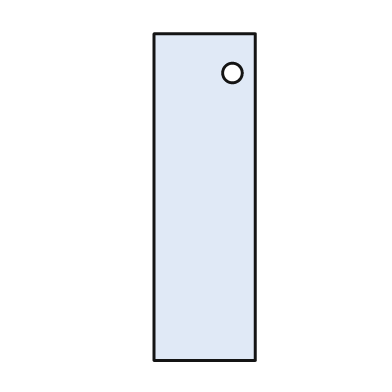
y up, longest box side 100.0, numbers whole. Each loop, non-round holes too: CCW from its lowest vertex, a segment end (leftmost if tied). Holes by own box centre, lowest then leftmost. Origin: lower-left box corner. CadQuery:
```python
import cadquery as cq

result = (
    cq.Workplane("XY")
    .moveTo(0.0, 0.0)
    .lineTo(31.0, 0.0)
    .lineTo(31.0, 100.0)
    .lineTo(0.0, 100.0)
    .close()
    .moveTo(24.0, 88.0)
    .circle(3.0)
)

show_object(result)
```